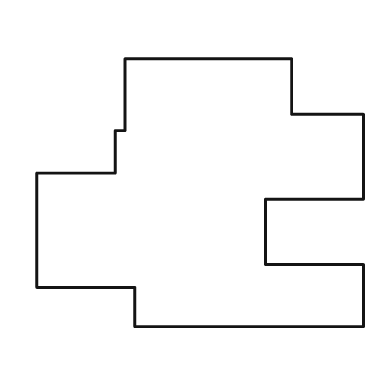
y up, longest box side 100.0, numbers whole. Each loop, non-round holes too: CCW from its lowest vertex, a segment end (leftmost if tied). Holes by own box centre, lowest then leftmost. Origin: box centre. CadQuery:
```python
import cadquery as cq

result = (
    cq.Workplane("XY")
    .moveTo(-20.0, -41.0)
    .lineTo(50.0, -41.0)
    .lineTo(50.0, -22.0)
    .lineTo(20.0, -22.0)
    .lineTo(20.0, -2.0)
    .lineTo(50.0, -2.0)
    .lineTo(50.0, 24.0)
    .lineTo(28.0, 24.0)
    .lineTo(28.0, 41.0)
    .lineTo(-23.0, 41.0)
    .lineTo(-23.0, 19.0)
    .lineTo(-26.0, 19.0)
    .lineTo(-26.0, 6.0)
    .lineTo(-50.0, 6.0)
    .lineTo(-50.0, -29.0)
    .lineTo(-20.0, -29.0)
    .close()
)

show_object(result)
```